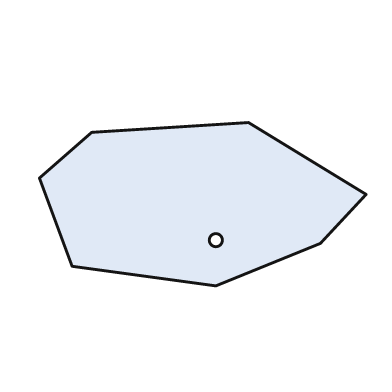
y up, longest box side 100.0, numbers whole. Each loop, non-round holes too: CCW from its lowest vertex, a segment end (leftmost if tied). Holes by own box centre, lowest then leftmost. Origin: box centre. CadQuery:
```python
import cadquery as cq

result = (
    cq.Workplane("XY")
    .moveTo(4.0, -25.0)
    .lineTo(36.0, -12.0)
    .lineTo(50.0, 3.0)
    .lineTo(14.0, 25.0)
    .lineTo(-34.0, 22.0)
    .lineTo(-50.0, 8.0)
    .lineTo(-40.0, -19.0)
    .close()
    .moveTo(4.0, -11.0)
    .circle(2.0)
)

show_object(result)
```